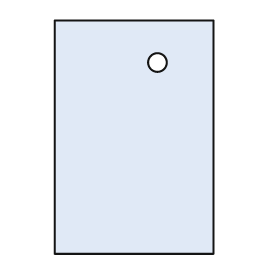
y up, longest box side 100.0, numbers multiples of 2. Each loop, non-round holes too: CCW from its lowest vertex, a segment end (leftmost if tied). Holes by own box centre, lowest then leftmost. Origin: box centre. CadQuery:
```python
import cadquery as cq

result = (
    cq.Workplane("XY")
    .moveTo(-34.0, -50.0)
    .lineTo(34.0, -50.0)
    .lineTo(34.0, 50.0)
    .lineTo(-34.0, 50.0)
    .close()
    .moveTo(10.0, 32.0)
    .circle(4.0)
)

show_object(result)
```